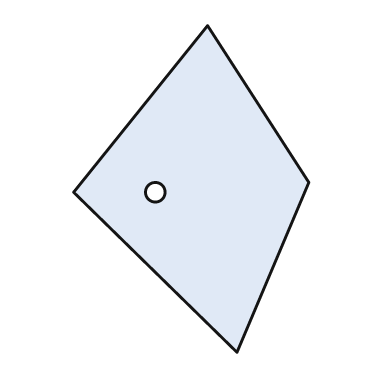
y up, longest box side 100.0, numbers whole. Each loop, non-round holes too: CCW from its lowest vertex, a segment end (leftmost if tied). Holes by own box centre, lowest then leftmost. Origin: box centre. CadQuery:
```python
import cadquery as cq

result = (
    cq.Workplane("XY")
    .moveTo(14.0, -50.0)
    .lineTo(36.0, 2.0)
    .lineTo(5.0, 50.0)
    .lineTo(-36.0, -1.0)
    .close()
    .moveTo(-11.0, -1.0)
    .circle(3.0)
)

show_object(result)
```